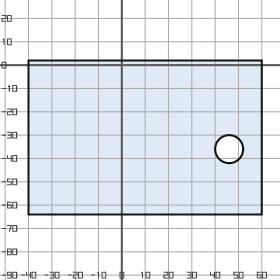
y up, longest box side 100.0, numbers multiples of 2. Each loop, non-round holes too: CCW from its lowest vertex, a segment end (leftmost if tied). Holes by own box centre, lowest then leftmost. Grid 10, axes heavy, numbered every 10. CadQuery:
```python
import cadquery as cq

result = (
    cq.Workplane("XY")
    .moveTo(-40.0, -64.0)
    .lineTo(60.0, -64.0)
    .lineTo(60.0, 2.0)
    .lineTo(-40.0, 2.0)
    .close()
    .moveTo(46.0, -36.0)
    .circle(6.0)
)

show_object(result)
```